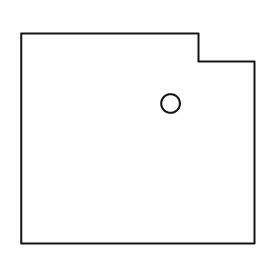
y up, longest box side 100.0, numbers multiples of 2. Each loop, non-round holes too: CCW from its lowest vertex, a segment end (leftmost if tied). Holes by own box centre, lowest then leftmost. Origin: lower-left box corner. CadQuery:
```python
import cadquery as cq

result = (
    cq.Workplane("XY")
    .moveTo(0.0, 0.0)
    .lineTo(100.0, 0.0)
    .lineTo(100.0, 78.0)
    .lineTo(76.0, 78.0)
    .lineTo(76.0, 90.0)
    .lineTo(0.0, 90.0)
    .close()
    .moveTo(64.0, 60.0)
    .circle(4.0)
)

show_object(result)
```